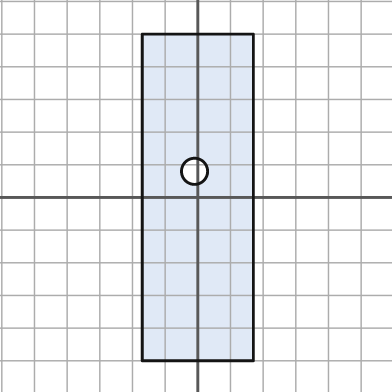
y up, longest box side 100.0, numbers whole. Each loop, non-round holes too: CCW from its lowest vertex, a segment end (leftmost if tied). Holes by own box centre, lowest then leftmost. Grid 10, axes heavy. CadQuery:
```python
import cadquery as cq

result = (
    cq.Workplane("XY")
    .moveTo(-17.0, -50.0)
    .lineTo(17.0, -50.0)
    .lineTo(17.0, 50.0)
    .lineTo(-17.0, 50.0)
    .close()
    .moveTo(-1.0, 8.0)
    .circle(4.0)
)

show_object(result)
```